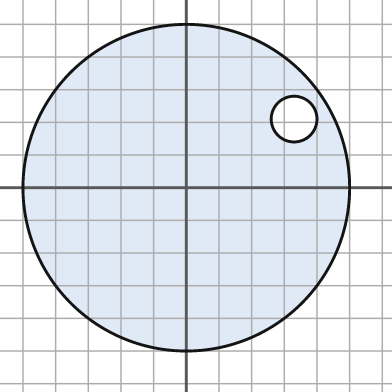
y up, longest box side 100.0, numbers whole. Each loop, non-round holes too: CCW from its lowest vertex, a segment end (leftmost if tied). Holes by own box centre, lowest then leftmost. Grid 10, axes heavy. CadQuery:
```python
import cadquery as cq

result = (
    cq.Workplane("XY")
    .moveTo(0.0, 0.0)
    .circle(50.0)
    .moveTo(33.0, 21.0)
    .circle(7.0)
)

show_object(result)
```